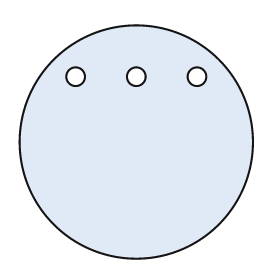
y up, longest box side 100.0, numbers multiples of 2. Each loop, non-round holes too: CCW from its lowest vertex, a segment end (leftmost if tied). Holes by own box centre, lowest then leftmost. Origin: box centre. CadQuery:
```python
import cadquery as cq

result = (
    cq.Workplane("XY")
    .moveTo(0.0, 0.0)
    .circle(50.0)
    .moveTo(-26.0, 28.0)
    .circle(4.0)
    .moveTo(0.0, 28.0)
    .circle(4.0)
    .moveTo(26.0, 28.0)
    .circle(4.0)
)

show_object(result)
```